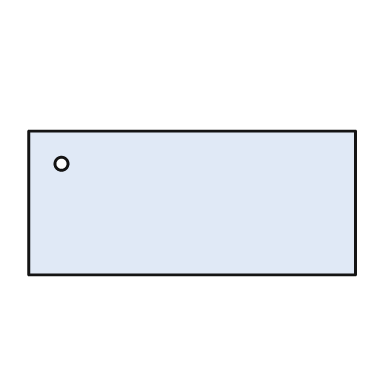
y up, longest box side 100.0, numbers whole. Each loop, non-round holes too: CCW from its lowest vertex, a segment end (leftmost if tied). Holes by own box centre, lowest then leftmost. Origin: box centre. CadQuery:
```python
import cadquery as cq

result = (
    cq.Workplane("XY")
    .moveTo(-50.0, -22.0)
    .lineTo(50.0, -22.0)
    .lineTo(50.0, 22.0)
    .lineTo(-50.0, 22.0)
    .close()
    .moveTo(-40.0, 12.0)
    .circle(2.0)
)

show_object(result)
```